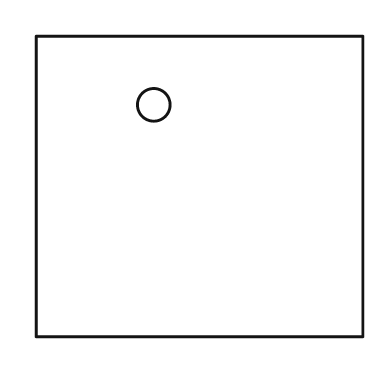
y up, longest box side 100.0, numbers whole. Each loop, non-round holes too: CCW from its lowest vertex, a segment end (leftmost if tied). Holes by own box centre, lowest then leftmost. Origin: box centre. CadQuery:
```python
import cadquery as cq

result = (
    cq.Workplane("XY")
    .moveTo(-50.0, -46.0)
    .lineTo(50.0, -46.0)
    .lineTo(50.0, 46.0)
    .lineTo(-50.0, 46.0)
    .close()
    .moveTo(-14.0, 25.0)
    .circle(5.0)
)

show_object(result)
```